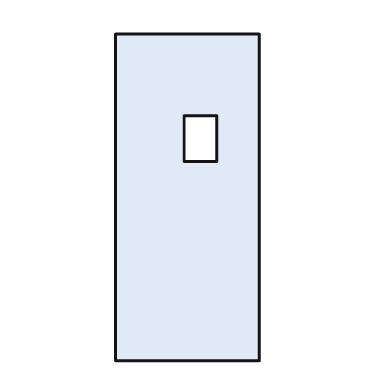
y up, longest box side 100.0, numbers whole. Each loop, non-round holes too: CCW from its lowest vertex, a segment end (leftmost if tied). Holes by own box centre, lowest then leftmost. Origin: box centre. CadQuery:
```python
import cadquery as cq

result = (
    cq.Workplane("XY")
    .moveTo(-22.0, -50.0)
    .lineTo(22.0, -50.0)
    .lineTo(22.0, 50.0)
    .lineTo(-22.0, 50.0)
    .close()
    .moveTo(-1.0, 11.0)
    .lineTo(9.0, 11.0)
    .lineTo(9.0, 25.0)
    .lineTo(-1.0, 25.0)
    .close()
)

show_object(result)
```